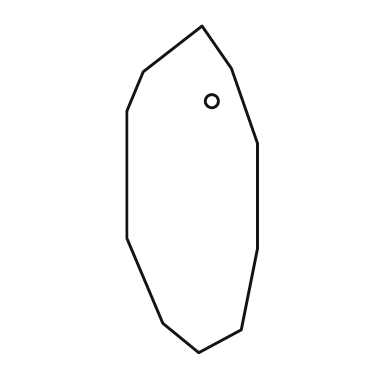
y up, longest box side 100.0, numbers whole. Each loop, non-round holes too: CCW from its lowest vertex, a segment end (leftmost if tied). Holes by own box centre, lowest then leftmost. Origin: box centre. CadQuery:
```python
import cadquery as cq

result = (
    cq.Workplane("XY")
    .moveTo(2.0, -50.0)
    .lineTo(15.0, -43.0)
    .lineTo(20.0, -18.0)
    .lineTo(20.0, 14.0)
    .lineTo(12.0, 37.0)
    .lineTo(3.0, 50.0)
    .lineTo(-15.0, 36.0)
    .lineTo(-20.0, 24.0)
    .lineTo(-20.0, -15.0)
    .lineTo(-9.0, -41.0)
    .close()
    .moveTo(6.0, 27.0)
    .circle(2.0)
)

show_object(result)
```